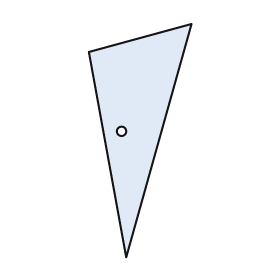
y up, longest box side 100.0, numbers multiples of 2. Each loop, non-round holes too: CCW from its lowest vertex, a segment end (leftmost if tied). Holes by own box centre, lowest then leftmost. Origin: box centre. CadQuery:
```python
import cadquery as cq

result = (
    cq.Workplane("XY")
    .moveTo(-6.0, -50.0)
    .lineTo(22.0, 50.0)
    .lineTo(-22.0, 38.0)
    .close()
    .moveTo(-8.0, 4.0)
    .circle(2.0)
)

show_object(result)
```